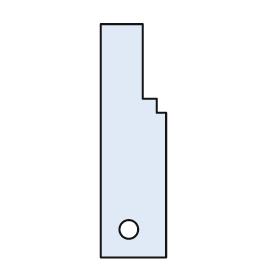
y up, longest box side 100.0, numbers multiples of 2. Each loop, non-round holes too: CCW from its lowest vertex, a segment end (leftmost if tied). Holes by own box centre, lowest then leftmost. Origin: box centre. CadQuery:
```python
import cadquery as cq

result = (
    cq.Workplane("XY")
    .moveTo(-14.0, -50.0)
    .lineTo(14.0, -50.0)
    .lineTo(14.0, 12.0)
    .lineTo(10.0, 12.0)
    .lineTo(10.0, 18.0)
    .lineTo(4.0, 18.0)
    .lineTo(4.0, 50.0)
    .lineTo(-14.0, 50.0)
    .close()
    .moveTo(-2.0, -38.0)
    .circle(4.0)
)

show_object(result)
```